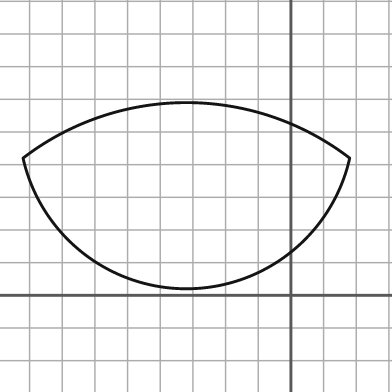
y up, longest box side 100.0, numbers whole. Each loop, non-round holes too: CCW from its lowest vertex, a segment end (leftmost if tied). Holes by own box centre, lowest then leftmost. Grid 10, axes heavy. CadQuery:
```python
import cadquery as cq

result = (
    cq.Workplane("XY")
    .moveTo(-82.0, 42.0)
    .threePointArc((-32.0, 2.0), (18.0, 42.0))
    .threePointArc((-32.0, 59.0), (-82.0, 42.0))
    .close()
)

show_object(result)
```